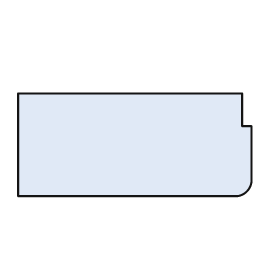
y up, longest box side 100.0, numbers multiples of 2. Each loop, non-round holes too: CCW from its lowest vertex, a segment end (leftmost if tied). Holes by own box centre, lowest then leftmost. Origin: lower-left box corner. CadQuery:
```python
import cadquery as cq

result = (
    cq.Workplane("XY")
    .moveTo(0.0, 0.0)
    .lineTo(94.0, 0.0)
    .threePointArc((98.0, 2.0), (100.0, 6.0))
    .lineTo(100.0, 30.0)
    .lineTo(96.0, 30.0)
    .lineTo(96.0, 44.0)
    .lineTo(0.0, 44.0)
    .close()
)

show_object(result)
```